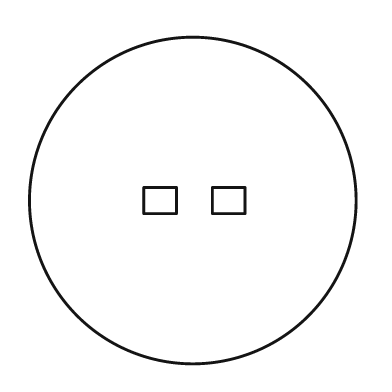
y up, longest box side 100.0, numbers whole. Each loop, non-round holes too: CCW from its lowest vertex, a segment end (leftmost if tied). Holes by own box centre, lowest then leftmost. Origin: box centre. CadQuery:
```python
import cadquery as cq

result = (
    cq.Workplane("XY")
    .moveTo(0.0, 0.0)
    .circle(50.0)
    .moveTo(-15.0, -4.0)
    .lineTo(-5.0, -4.0)
    .lineTo(-5.0, 4.0)
    .lineTo(-15.0, 4.0)
    .close()
    .moveTo(6.0, -4.0)
    .lineTo(16.0, -4.0)
    .lineTo(16.0, 4.0)
    .lineTo(6.0, 4.0)
    .close()
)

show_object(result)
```